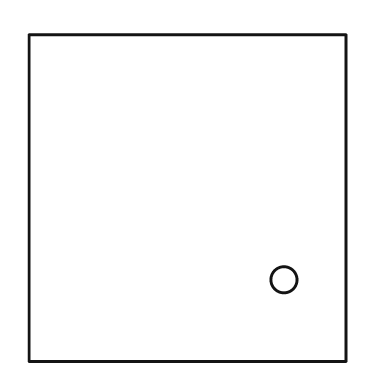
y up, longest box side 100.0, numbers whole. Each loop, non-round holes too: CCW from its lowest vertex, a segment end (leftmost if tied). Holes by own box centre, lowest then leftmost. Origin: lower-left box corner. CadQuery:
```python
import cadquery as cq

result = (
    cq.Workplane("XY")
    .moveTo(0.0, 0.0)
    .lineTo(97.0, 0.0)
    .lineTo(97.0, 100.0)
    .lineTo(0.0, 100.0)
    .close()
    .moveTo(78.0, 25.0)
    .circle(4.0)
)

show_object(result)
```